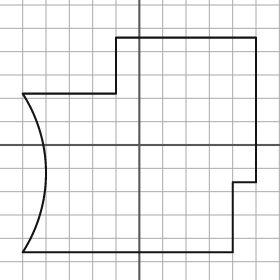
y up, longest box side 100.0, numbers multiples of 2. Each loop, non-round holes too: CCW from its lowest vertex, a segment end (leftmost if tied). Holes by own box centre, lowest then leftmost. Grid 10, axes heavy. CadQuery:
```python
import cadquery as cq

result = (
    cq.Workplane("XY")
    .moveTo(-50.0, -46.0)
    .lineTo(40.0, -46.0)
    .lineTo(40.0, -16.0)
    .lineTo(50.0, -16.0)
    .lineTo(50.0, 46.0)
    .lineTo(-10.0, 46.0)
    .lineTo(-10.0, 22.0)
    .lineTo(-50.0, 22.0)
    .threePointArc((-40.0, -12.0), (-50.0, -46.0))
    .close()
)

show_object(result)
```